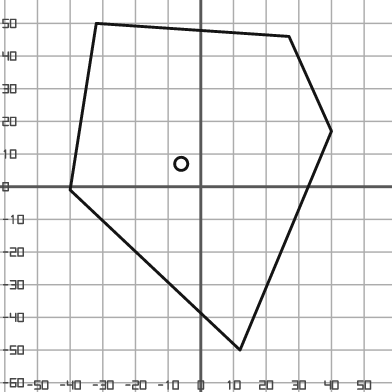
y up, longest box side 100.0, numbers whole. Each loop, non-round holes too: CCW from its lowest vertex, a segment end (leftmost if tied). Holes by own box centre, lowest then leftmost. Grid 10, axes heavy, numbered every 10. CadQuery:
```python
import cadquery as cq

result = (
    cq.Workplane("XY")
    .moveTo(12.0, -50.0)
    .lineTo(40.0, 17.0)
    .lineTo(27.0, 46.0)
    .lineTo(-32.0, 50.0)
    .lineTo(-40.0, -1.0)
    .close()
    .moveTo(-6.0, 7.0)
    .circle(2.0)
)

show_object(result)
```